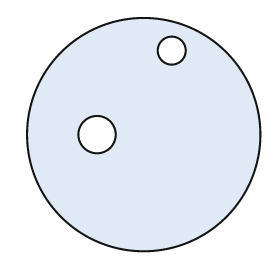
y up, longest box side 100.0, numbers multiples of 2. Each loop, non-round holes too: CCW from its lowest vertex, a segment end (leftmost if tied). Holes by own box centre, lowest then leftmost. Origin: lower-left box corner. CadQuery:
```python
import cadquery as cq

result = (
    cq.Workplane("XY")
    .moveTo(50.0, 50.0)
    .circle(50.0)
    .moveTo(30.0, 50.0)
    .circle(8.0)
    .moveTo(62.0, 86.0)
    .circle(6.0)
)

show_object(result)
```